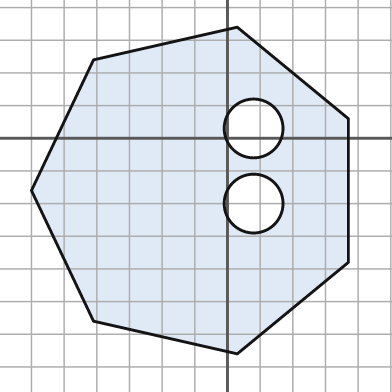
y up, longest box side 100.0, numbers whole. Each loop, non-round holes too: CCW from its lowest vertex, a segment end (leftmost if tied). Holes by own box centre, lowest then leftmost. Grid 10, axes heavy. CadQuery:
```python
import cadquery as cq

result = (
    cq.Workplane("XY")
    .moveTo(3.0, -66.0)
    .lineTo(37.0, -38.0)
    .lineTo(37.0, 6.0)
    .lineTo(3.0, 34.0)
    .lineTo(-41.0, 24.0)
    .lineTo(-60.0, -16.0)
    .lineTo(-41.0, -56.0)
    .close()
    .moveTo(8.0, -20.0)
    .circle(9.0)
    .moveTo(8.0, 3.0)
    .circle(9.0)
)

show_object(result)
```